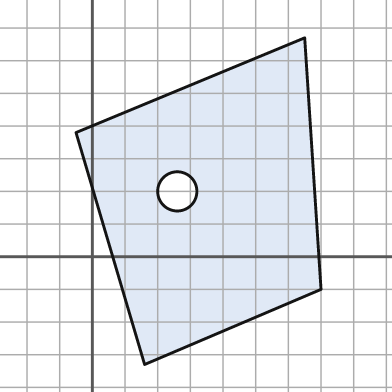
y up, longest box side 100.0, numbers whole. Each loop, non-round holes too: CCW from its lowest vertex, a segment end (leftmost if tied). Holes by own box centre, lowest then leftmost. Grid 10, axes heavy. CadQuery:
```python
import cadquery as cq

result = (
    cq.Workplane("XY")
    .moveTo(16.0, -33.0)
    .lineTo(70.0, -10.0)
    .lineTo(65.0, 67.0)
    .lineTo(-5.0, 38.0)
    .close()
    .moveTo(26.0, 20.0)
    .circle(6.0)
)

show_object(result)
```